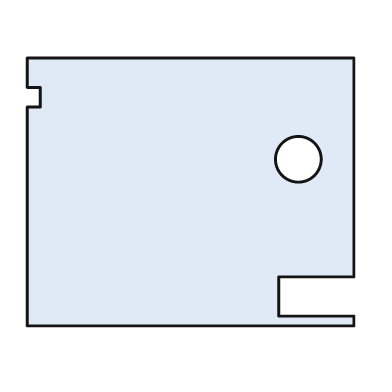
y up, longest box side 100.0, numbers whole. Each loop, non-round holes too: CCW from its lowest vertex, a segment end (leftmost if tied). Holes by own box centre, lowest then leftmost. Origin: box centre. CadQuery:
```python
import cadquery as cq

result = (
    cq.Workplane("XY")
    .moveTo(-50.0, -41.0)
    .lineTo(50.0, -41.0)
    .lineTo(50.0, -38.0)
    .lineTo(27.0, -38.0)
    .lineTo(27.0, -26.0)
    .lineTo(50.0, -26.0)
    .lineTo(50.0, 41.0)
    .lineTo(-50.0, 41.0)
    .lineTo(-50.0, 32.0)
    .lineTo(-46.0, 32.0)
    .lineTo(-46.0, 26.0)
    .lineTo(-50.0, 26.0)
    .close()
    .moveTo(33.0, 10.0)
    .circle(7.0)
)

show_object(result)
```